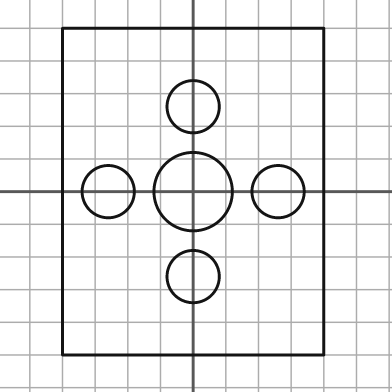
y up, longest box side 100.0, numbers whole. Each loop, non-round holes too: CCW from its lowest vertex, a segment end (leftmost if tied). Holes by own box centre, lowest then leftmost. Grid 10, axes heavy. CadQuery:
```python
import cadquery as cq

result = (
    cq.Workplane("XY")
    .moveTo(-40.0, -50.0)
    .lineTo(40.0, -50.0)
    .lineTo(40.0, 50.0)
    .lineTo(-40.0, 50.0)
    .close()
    .moveTo(0.0, -26.0)
    .circle(8.0)
    .moveTo(-26.0, 0.0)
    .circle(8.0)
    .moveTo(0.0, 0.0)
    .circle(12.0)
    .moveTo(26.0, 0.0)
    .circle(8.0)
    .moveTo(0.0, 26.0)
    .circle(8.0)
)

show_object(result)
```